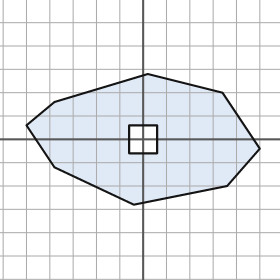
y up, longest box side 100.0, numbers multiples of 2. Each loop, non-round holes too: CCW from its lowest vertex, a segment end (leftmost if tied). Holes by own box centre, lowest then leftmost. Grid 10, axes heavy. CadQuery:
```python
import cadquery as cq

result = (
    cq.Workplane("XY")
    .moveTo(-4.0, -28.0)
    .lineTo(36.0, -20.0)
    .lineTo(50.0, -4.0)
    .lineTo(34.0, 20.0)
    .lineTo(2.0, 28.0)
    .lineTo(-38.0, 16.0)
    .lineTo(-50.0, 6.0)
    .lineTo(-38.0, -12.0)
    .close()
    .moveTo(-6.0, -6.0)
    .lineTo(6.0, -6.0)
    .lineTo(6.0, 6.0)
    .lineTo(-6.0, 6.0)
    .close()
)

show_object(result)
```